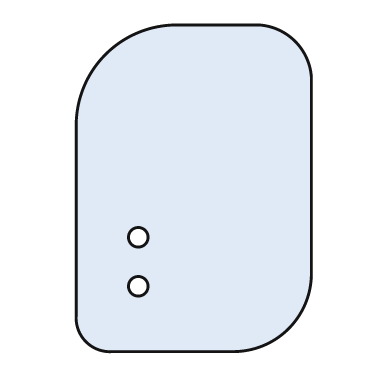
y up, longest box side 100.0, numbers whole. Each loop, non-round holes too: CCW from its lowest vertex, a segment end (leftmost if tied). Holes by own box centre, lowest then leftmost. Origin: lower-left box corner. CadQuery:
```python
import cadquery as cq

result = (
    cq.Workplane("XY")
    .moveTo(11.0, 0.0)
    .lineTo(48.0, 0.0)
    .threePointArc((65.0, 7.0), (72.0, 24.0))
    .lineTo(72.0, 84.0)
    .threePointArc((67.0, 95.0), (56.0, 100.0))
    .lineTo(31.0, 100.0)
    .threePointArc((9.0, 91.0), (0.0, 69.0))
    .lineTo(0.0, 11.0)
    .threePointArc((3.0, 3.0), (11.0, 0.0))
    .close()
    .moveTo(19.0, 20.0)
    .circle(3.0)
    .moveTo(19.0, 35.0)
    .circle(3.0)
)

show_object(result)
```